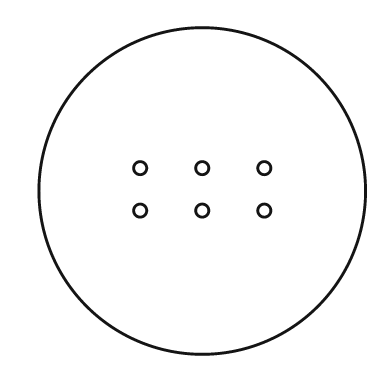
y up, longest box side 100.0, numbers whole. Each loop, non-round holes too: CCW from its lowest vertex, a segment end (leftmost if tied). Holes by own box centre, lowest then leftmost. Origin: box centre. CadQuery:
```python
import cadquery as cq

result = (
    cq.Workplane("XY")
    .moveTo(0.0, 0.0)
    .circle(50.0)
    .moveTo(-19.0, -6.0)
    .circle(2.0)
    .moveTo(0.0, -6.0)
    .circle(2.0)
    .moveTo(19.0, -6.0)
    .circle(2.0)
    .moveTo(-19.0, 7.0)
    .circle(2.0)
    .moveTo(0.0, 7.0)
    .circle(2.0)
    .moveTo(19.0, 7.0)
    .circle(2.0)
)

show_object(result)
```